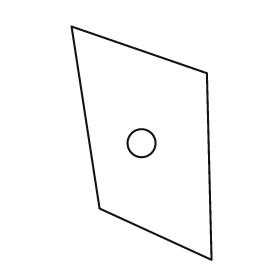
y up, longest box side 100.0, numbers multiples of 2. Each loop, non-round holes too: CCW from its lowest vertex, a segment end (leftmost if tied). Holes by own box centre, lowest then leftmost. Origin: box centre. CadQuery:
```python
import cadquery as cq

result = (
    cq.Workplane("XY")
    .moveTo(30.0, -50.0)
    .lineTo(28.0, 30.0)
    .lineTo(-30.0, 50.0)
    .lineTo(-18.0, -28.0)
    .close()
    .moveTo(0.0, 0.0)
    .circle(6.0)
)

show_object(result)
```